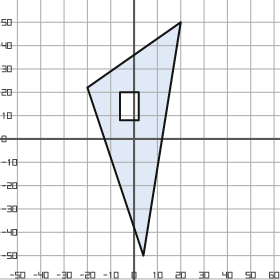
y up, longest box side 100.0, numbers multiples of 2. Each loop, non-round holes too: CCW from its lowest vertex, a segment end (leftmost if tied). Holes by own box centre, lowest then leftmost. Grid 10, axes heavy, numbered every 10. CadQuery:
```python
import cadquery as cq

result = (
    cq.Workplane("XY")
    .moveTo(4.0, -50.0)
    .lineTo(20.0, 50.0)
    .lineTo(-20.0, 22.0)
    .close()
    .moveTo(-6.0, 8.0)
    .lineTo(2.0, 8.0)
    .lineTo(2.0, 20.0)
    .lineTo(-6.0, 20.0)
    .close()
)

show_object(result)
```